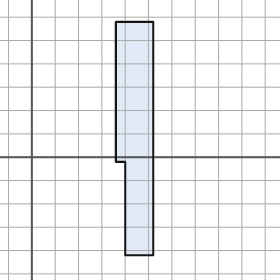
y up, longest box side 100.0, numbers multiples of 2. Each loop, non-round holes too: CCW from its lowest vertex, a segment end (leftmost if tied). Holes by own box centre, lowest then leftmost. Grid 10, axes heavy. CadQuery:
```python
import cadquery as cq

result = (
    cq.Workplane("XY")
    .moveTo(40.0, -42.0)
    .lineTo(52.0, -42.0)
    .lineTo(52.0, 58.0)
    .lineTo(36.0, 58.0)
    .lineTo(36.0, -2.0)
    .lineTo(40.0, -2.0)
    .close()
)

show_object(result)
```